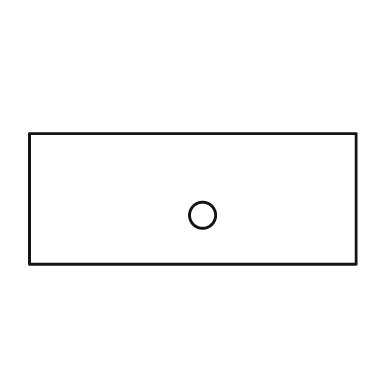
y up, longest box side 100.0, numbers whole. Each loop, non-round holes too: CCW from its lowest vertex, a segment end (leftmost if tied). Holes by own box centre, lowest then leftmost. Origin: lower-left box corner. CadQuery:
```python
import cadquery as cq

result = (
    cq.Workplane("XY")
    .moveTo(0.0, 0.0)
    .lineTo(100.0, 0.0)
    .lineTo(100.0, 40.0)
    .lineTo(0.0, 40.0)
    .close()
    .moveTo(53.0, 15.0)
    .circle(4.0)
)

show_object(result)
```